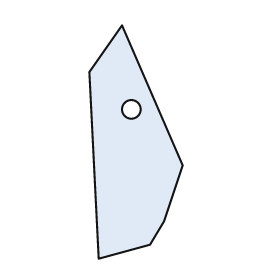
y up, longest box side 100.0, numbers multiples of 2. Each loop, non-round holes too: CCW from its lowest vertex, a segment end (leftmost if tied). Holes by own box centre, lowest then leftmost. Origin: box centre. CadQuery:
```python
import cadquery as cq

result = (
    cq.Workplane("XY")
    .moveTo(-16.0, -50.0)
    .lineTo(6.0, -44.0)
    .lineTo(12.0, -34.0)
    .lineTo(20.0, -10.0)
    .lineTo(-6.0, 50.0)
    .lineTo(-20.0, 30.0)
    .close()
    .moveTo(-2.0, 14.0)
    .circle(4.0)
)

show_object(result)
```